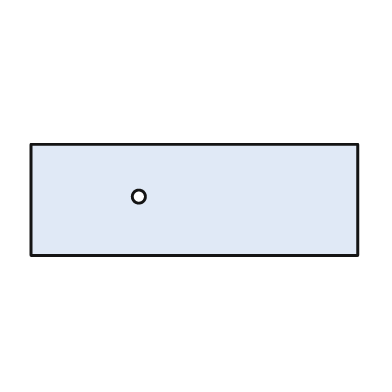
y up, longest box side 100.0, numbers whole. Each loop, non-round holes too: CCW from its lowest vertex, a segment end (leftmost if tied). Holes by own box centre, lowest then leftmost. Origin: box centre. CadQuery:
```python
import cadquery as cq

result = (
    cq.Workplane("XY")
    .moveTo(-50.0, -17.0)
    .lineTo(50.0, -17.0)
    .lineTo(50.0, 17.0)
    .lineTo(-50.0, 17.0)
    .close()
    .moveTo(-17.0, 1.0)
    .circle(2.0)
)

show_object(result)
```